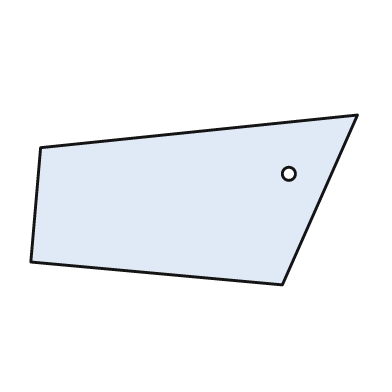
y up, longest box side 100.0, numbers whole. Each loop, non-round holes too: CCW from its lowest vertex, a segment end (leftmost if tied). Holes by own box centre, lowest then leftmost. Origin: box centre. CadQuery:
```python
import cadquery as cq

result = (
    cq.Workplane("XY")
    .moveTo(27.0, -26.0)
    .lineTo(50.0, 26.0)
    .lineTo(-47.0, 16.0)
    .lineTo(-50.0, -19.0)
    .close()
    .moveTo(29.0, 8.0)
    .circle(2.0)
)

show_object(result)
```